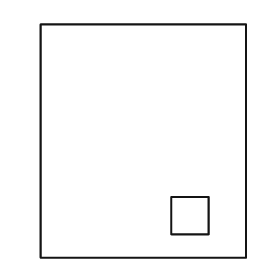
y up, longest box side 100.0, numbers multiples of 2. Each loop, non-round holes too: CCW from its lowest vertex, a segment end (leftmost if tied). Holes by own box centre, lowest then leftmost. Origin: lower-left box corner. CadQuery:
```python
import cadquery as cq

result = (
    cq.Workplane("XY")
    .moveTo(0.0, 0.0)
    .lineTo(88.0, 0.0)
    .lineTo(88.0, 100.0)
    .lineTo(0.0, 100.0)
    .close()
    .moveTo(56.0, 10.0)
    .lineTo(72.0, 10.0)
    .lineTo(72.0, 26.0)
    .lineTo(56.0, 26.0)
    .close()
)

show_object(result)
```